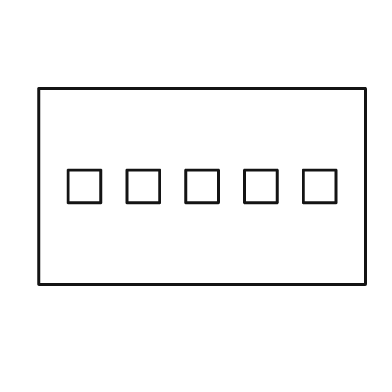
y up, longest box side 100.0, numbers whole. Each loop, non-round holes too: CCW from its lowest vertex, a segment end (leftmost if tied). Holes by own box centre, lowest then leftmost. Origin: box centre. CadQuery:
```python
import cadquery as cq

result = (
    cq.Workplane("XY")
    .moveTo(-50.0, -30.0)
    .lineTo(50.0, -30.0)
    .lineTo(50.0, 30.0)
    .lineTo(-50.0, 30.0)
    .close()
    .moveTo(-41.0, -5.0)
    .lineTo(-31.0, -5.0)
    .lineTo(-31.0, 5.0)
    .lineTo(-41.0, 5.0)
    .close()
    .moveTo(-23.0, -5.0)
    .lineTo(-13.0, -5.0)
    .lineTo(-13.0, 5.0)
    .lineTo(-23.0, 5.0)
    .close()
    .moveTo(-5.0, -5.0)
    .lineTo(5.0, -5.0)
    .lineTo(5.0, 5.0)
    .lineTo(-5.0, 5.0)
    .close()
    .moveTo(13.0, -5.0)
    .lineTo(23.0, -5.0)
    .lineTo(23.0, 5.0)
    .lineTo(13.0, 5.0)
    .close()
    .moveTo(31.0, -5.0)
    .lineTo(41.0, -5.0)
    .lineTo(41.0, 5.0)
    .lineTo(31.0, 5.0)
    .close()
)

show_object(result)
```